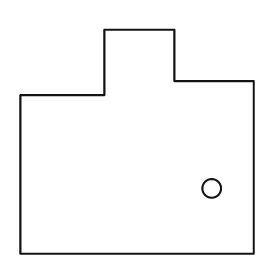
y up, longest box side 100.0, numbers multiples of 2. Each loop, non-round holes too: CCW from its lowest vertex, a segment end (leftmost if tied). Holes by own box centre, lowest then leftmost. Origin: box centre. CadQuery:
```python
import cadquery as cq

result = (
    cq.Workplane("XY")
    .moveTo(-50.0, -48.0)
    .lineTo(50.0, -48.0)
    .lineTo(50.0, 26.0)
    .lineTo(16.0, 26.0)
    .lineTo(16.0, 48.0)
    .lineTo(-14.0, 48.0)
    .lineTo(-14.0, 20.0)
    .lineTo(-50.0, 20.0)
    .close()
    .moveTo(32.0, -20.0)
    .circle(4.0)
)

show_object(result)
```